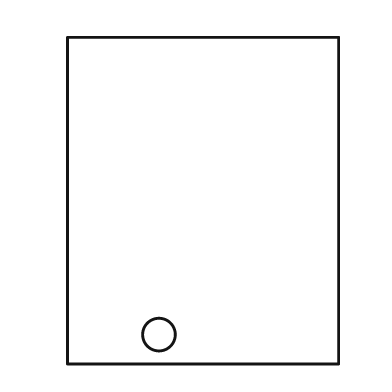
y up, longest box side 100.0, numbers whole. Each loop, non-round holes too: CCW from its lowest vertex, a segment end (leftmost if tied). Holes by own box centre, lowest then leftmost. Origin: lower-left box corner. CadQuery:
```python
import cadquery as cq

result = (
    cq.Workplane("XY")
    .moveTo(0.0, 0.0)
    .lineTo(83.0, 0.0)
    .lineTo(83.0, 100.0)
    .lineTo(0.0, 100.0)
    .close()
    .moveTo(28.0, 9.0)
    .circle(5.0)
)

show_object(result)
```